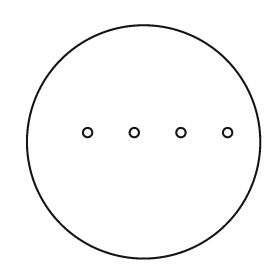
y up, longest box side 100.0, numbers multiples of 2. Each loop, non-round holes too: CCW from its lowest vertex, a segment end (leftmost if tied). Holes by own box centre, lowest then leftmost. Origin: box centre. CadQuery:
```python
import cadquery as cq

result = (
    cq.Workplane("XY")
    .moveTo(0.0, 0.0)
    .circle(50.0)
    .moveTo(-24.0, 4.0)
    .circle(2.0)
    .moveTo(-4.0, 4.0)
    .circle(2.0)
    .moveTo(16.0, 4.0)
    .circle(2.0)
    .moveTo(36.0, 4.0)
    .circle(2.0)
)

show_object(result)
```